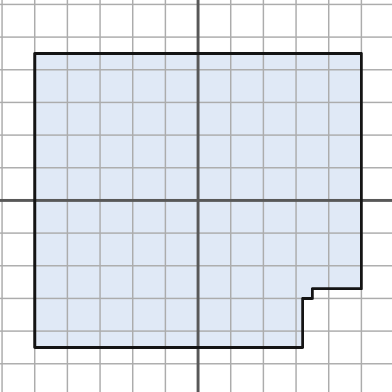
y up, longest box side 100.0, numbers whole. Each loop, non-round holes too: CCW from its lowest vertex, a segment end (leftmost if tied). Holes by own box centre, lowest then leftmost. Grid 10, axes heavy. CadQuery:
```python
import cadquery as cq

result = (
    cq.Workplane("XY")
    .moveTo(-50.0, -45.0)
    .lineTo(32.0, -45.0)
    .lineTo(32.0, -30.0)
    .lineTo(35.0, -30.0)
    .lineTo(35.0, -27.0)
    .lineTo(50.0, -27.0)
    .lineTo(50.0, 45.0)
    .lineTo(-50.0, 45.0)
    .close()
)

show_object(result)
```